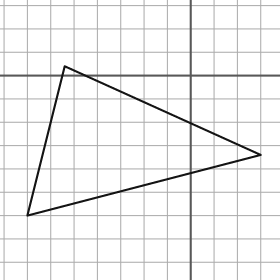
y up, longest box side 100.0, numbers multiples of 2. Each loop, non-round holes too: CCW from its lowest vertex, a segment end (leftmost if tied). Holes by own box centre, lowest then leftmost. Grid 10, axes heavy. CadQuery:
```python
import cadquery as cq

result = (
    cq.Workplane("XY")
    .moveTo(-70.0, -60.0)
    .lineTo(30.0, -34.0)
    .lineTo(-54.0, 4.0)
    .close()
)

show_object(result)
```